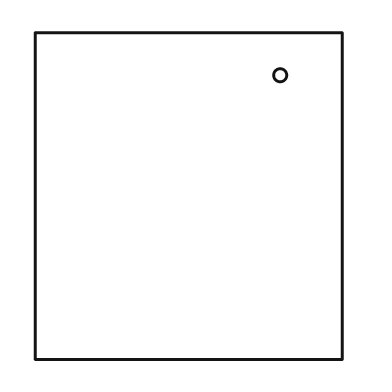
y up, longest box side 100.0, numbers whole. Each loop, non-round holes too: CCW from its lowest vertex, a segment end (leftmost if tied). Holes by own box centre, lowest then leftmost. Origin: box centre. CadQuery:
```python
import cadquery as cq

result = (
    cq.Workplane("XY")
    .moveTo(-47.0, -50.0)
    .lineTo(47.0, -50.0)
    .lineTo(47.0, 50.0)
    .lineTo(-47.0, 50.0)
    .close()
    .moveTo(28.0, 37.0)
    .circle(2.0)
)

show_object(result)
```